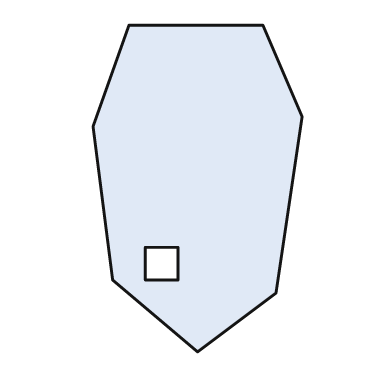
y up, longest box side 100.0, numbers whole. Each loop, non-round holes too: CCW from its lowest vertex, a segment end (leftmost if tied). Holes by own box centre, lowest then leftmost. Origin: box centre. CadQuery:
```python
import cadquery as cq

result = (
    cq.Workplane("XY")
    .moveTo(0.0, -50.0)
    .lineTo(24.0, -32.0)
    .lineTo(32.0, 22.0)
    .lineTo(20.0, 50.0)
    .lineTo(-21.0, 50.0)
    .lineTo(-32.0, 19.0)
    .lineTo(-26.0, -28.0)
    .close()
    .moveTo(-16.0, -28.0)
    .lineTo(-6.0, -28.0)
    .lineTo(-6.0, -18.0)
    .lineTo(-16.0, -18.0)
    .close()
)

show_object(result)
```